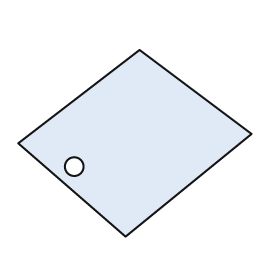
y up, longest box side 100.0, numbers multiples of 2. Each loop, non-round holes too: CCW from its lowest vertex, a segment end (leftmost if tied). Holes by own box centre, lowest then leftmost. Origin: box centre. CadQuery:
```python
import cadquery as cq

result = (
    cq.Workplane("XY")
    .moveTo(-4.0, -40.0)
    .lineTo(50.0, 4.0)
    .lineTo(2.0, 40.0)
    .lineTo(-50.0, 0.0)
    .close()
    .moveTo(-26.0, -10.0)
    .circle(4.0)
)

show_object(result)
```